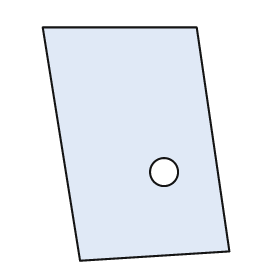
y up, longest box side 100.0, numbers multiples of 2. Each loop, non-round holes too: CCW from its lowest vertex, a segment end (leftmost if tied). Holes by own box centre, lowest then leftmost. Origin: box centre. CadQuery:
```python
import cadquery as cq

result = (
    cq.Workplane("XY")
    .moveTo(-24.0, -50.0)
    .lineTo(40.0, -46.0)
    .lineTo(26.0, 50.0)
    .lineTo(-40.0, 50.0)
    .close()
    .moveTo(12.0, -12.0)
    .circle(6.0)
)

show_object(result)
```